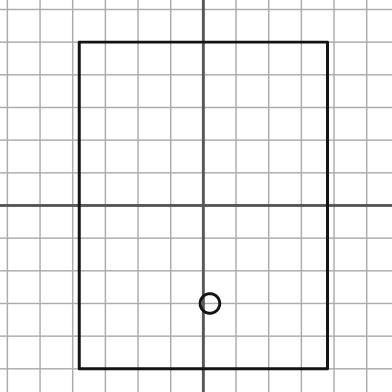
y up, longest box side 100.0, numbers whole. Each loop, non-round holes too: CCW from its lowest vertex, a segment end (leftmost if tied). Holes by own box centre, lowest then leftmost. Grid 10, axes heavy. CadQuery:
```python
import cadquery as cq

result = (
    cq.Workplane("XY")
    .moveTo(-38.0, -50.0)
    .lineTo(38.0, -50.0)
    .lineTo(38.0, 50.0)
    .lineTo(-38.0, 50.0)
    .close()
    .moveTo(2.0, -30.0)
    .circle(3.0)
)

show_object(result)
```